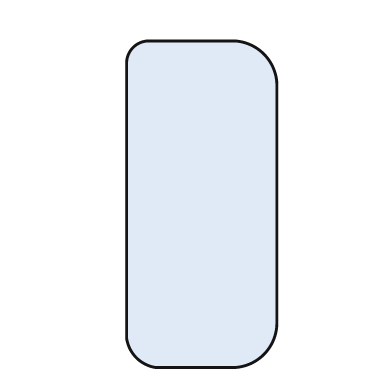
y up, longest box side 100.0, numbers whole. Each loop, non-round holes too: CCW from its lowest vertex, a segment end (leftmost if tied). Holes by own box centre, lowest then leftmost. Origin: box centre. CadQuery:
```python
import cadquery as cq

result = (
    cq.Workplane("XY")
    .moveTo(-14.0, -50.0)
    .lineTo(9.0, -50.0)
    .threePointArc((19.0, -46.0), (23.0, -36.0))
    .lineTo(23.0, 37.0)
    .threePointArc((19.0, 46.0), (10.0, 50.0))
    .lineTo(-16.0, 50.0)
    .threePointArc((-21.0, 48.0), (-23.0, 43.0))
    .lineTo(-23.0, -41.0)
    .threePointArc((-20.0, -47.0), (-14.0, -50.0))
    .close()
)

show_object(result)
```